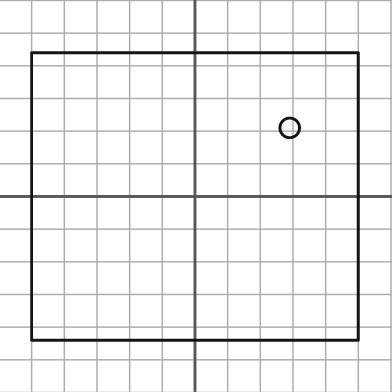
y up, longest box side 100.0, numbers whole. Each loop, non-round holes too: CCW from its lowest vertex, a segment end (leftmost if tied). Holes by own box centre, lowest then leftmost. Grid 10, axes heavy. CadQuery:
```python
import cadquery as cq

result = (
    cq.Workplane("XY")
    .moveTo(-50.0, -44.0)
    .lineTo(50.0, -44.0)
    .lineTo(50.0, 44.0)
    .lineTo(-50.0, 44.0)
    .close()
    .moveTo(29.0, 21.0)
    .circle(3.0)
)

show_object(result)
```